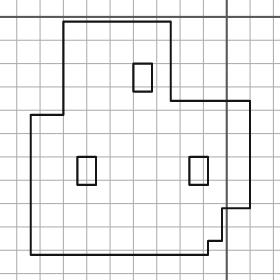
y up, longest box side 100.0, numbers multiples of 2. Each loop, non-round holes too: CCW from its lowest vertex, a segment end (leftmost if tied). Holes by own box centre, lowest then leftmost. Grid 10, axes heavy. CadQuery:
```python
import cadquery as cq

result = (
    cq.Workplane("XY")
    .moveTo(-84.0, -102.0)
    .lineTo(-8.0, -102.0)
    .lineTo(-8.0, -96.0)
    .lineTo(-2.0, -96.0)
    .lineTo(-2.0, -82.0)
    .lineTo(10.0, -82.0)
    .lineTo(10.0, -36.0)
    .lineTo(-24.0, -36.0)
    .lineTo(-24.0, -2.0)
    .lineTo(-70.0, -2.0)
    .lineTo(-70.0, -42.0)
    .lineTo(-84.0, -42.0)
    .close()
    .moveTo(-64.0, -72.0)
    .lineTo(-56.0, -72.0)
    .lineTo(-56.0, -60.0)
    .lineTo(-64.0, -60.0)
    .close()
    .moveTo(-16.0, -72.0)
    .lineTo(-8.0, -72.0)
    .lineTo(-8.0, -60.0)
    .lineTo(-16.0, -60.0)
    .close()
    .moveTo(-40.0, -32.0)
    .lineTo(-32.0, -32.0)
    .lineTo(-32.0, -20.0)
    .lineTo(-40.0, -20.0)
    .close()
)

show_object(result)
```